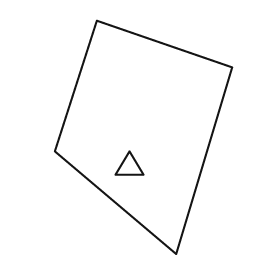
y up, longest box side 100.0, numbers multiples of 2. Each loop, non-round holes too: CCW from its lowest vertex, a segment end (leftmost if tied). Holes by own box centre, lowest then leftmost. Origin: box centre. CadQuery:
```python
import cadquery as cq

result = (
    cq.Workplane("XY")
    .moveTo(14.0, -50.0)
    .lineTo(38.0, 30.0)
    .lineTo(-20.0, 50.0)
    .lineTo(-38.0, -6.0)
    .close()
    .moveTo(-12.0, -16.0)
    .lineTo(0.0, -16.0)
    .lineTo(-6.0, -6.0)
    .close()
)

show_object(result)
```